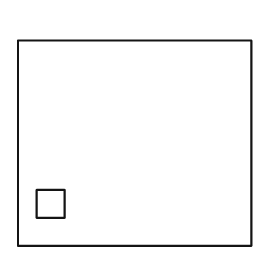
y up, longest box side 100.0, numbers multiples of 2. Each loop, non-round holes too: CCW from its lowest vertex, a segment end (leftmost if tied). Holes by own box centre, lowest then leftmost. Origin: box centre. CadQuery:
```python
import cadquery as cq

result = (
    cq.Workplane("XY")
    .moveTo(-50.0, -44.0)
    .lineTo(50.0, -44.0)
    .lineTo(50.0, 44.0)
    .lineTo(-50.0, 44.0)
    .close()
    .moveTo(-42.0, -32.0)
    .lineTo(-30.0, -32.0)
    .lineTo(-30.0, -20.0)
    .lineTo(-42.0, -20.0)
    .close()
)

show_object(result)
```